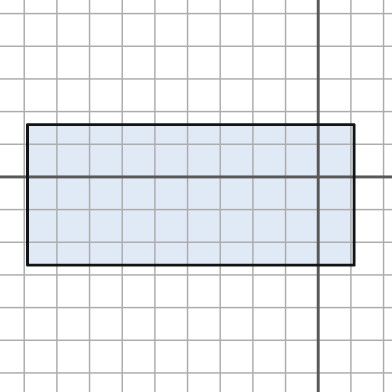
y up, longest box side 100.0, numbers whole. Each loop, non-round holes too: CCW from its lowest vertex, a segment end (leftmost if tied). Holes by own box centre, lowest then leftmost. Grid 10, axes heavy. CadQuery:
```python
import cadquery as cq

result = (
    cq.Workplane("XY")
    .moveTo(-89.0, -27.0)
    .lineTo(11.0, -27.0)
    .lineTo(11.0, 16.0)
    .lineTo(-89.0, 16.0)
    .close()
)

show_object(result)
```